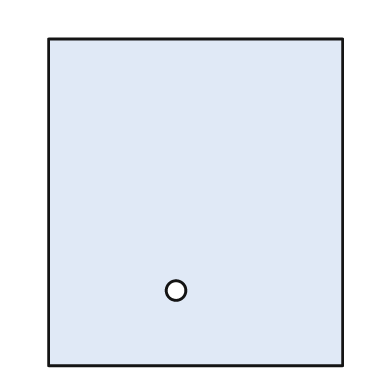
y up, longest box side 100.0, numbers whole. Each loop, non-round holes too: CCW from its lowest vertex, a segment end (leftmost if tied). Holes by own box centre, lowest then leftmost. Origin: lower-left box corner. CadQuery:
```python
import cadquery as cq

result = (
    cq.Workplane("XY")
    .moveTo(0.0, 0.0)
    .lineTo(90.0, 0.0)
    .lineTo(90.0, 100.0)
    .lineTo(0.0, 100.0)
    .close()
    .moveTo(39.0, 23.0)
    .circle(3.0)
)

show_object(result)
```